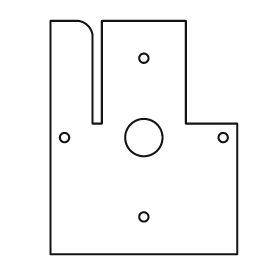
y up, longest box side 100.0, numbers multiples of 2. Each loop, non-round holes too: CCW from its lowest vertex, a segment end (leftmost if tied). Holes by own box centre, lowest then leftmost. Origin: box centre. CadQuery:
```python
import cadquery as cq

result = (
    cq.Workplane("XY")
    .moveTo(-40.0, -50.0)
    .lineTo(40.0, -50.0)
    .lineTo(40.0, 6.0)
    .lineTo(18.0, 6.0)
    .lineTo(18.0, 50.0)
    .lineTo(-18.0, 50.0)
    .lineTo(-18.0, 6.0)
    .lineTo(-22.0, 6.0)
    .lineTo(-22.0, 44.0)
    .threePointArc((-24.0, 48.0), (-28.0, 50.0))
    .lineTo(-40.0, 50.0)
    .close()
    .moveTo(0.0, -34.0)
    .circle(2.0)
    .moveTo(-34.0, 0.0)
    .circle(2.0)
    .moveTo(0.0, 0.0)
    .circle(8.0)
    .moveTo(34.0, 0.0)
    .circle(2.0)
    .moveTo(0.0, 34.0)
    .circle(2.0)
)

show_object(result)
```